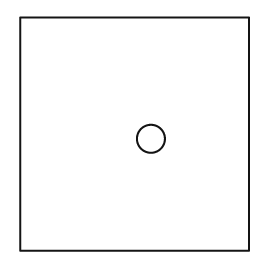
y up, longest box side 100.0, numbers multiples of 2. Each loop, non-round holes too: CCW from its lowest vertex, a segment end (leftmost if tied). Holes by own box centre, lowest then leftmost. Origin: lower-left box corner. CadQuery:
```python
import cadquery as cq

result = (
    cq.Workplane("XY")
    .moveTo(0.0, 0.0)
    .lineTo(98.0, 0.0)
    .lineTo(98.0, 100.0)
    .lineTo(0.0, 100.0)
    .close()
    .moveTo(56.0, 48.0)
    .circle(6.0)
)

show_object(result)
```